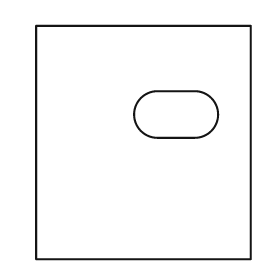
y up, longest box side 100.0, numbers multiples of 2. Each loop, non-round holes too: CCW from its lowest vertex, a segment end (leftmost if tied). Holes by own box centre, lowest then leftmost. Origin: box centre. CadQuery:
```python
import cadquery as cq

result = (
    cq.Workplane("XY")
    .moveTo(-46.0, -50.0)
    .lineTo(46.0, -50.0)
    .lineTo(46.0, 50.0)
    .lineTo(-46.0, 50.0)
    .close()
    .moveTo(6.0, 2.0)
    .lineTo(22.0, 2.0)
    .threePointArc((32.0, 12.0), (22.0, 22.0))
    .lineTo(6.0, 22.0)
    .threePointArc((-4.0, 12.0), (6.0, 2.0))
    .close()
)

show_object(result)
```